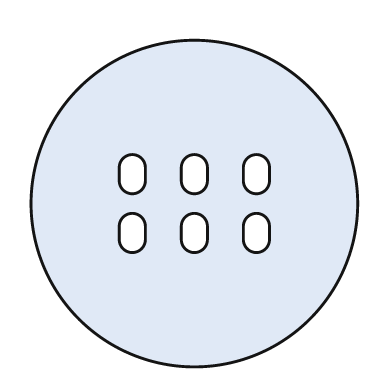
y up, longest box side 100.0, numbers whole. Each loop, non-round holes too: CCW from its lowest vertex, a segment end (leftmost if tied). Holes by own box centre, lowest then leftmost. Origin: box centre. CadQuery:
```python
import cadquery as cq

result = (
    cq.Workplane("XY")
    .moveTo(0.0, 0.0)
    .circle(50.0)
    .moveTo(-23.0, -11.0)
    .threePointArc((-19.0, -15.0), (-15.0, -11.0))
    .lineTo(-15.0, -7.0)
    .threePointArc((-19.0, -3.0), (-23.0, -7.0))
    .close()
    .moveTo(-4.0, -11.0)
    .threePointArc((0.0, -15.0), (4.0, -11.0))
    .lineTo(4.0, -7.0)
    .threePointArc((0.0, -3.0), (-4.0, -7.0))
    .close()
    .moveTo(15.0, -11.0)
    .threePointArc((19.0, -15.0), (23.0, -11.0))
    .lineTo(23.0, -7.0)
    .threePointArc((19.0, -3.0), (15.0, -7.0))
    .close()
    .moveTo(-23.0, 7.0)
    .threePointArc((-19.0, 3.0), (-15.0, 7.0))
    .lineTo(-15.0, 11.0)
    .threePointArc((-19.0, 15.0), (-23.0, 11.0))
    .close()
    .moveTo(-4.0, 7.0)
    .threePointArc((0.0, 3.0), (4.0, 7.0))
    .lineTo(4.0, 11.0)
    .threePointArc((0.0, 15.0), (-4.0, 11.0))
    .close()
    .moveTo(15.0, 7.0)
    .threePointArc((19.0, 3.0), (23.0, 7.0))
    .lineTo(23.0, 11.0)
    .threePointArc((19.0, 15.0), (15.0, 11.0))
    .close()
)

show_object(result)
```